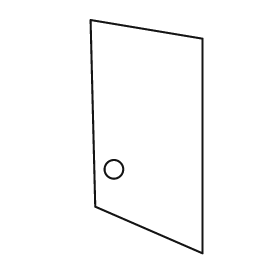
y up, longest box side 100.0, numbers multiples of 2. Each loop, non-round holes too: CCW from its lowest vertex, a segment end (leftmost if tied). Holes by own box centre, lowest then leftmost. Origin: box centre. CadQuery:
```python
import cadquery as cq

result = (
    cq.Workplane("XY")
    .moveTo(24.0, -50.0)
    .lineTo(24.0, 42.0)
    .lineTo(-24.0, 50.0)
    .lineTo(-22.0, -30.0)
    .close()
    .moveTo(-14.0, -14.0)
    .circle(4.0)
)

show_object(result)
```